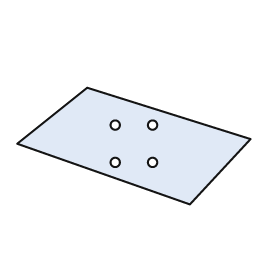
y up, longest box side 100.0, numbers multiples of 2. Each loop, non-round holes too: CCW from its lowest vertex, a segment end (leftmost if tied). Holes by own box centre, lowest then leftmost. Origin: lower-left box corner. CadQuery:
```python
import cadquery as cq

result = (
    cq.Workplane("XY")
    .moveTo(74.0, 0.0)
    .lineTo(100.0, 28.0)
    .lineTo(30.0, 50.0)
    .lineTo(0.0, 26.0)
    .close()
    .moveTo(42.0, 18.0)
    .circle(2.0)
    .moveTo(58.0, 18.0)
    .circle(2.0)
    .moveTo(42.0, 34.0)
    .circle(2.0)
    .moveTo(58.0, 34.0)
    .circle(2.0)
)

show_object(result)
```